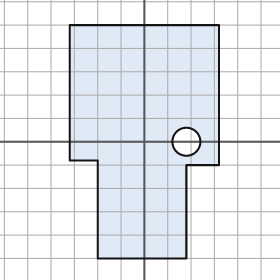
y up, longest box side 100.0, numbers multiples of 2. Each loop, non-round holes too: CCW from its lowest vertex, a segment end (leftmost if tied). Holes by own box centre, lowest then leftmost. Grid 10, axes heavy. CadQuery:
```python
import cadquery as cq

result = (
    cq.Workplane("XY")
    .moveTo(-20.0, -50.0)
    .lineTo(18.0, -50.0)
    .lineTo(18.0, -10.0)
    .lineTo(32.0, -10.0)
    .lineTo(32.0, 50.0)
    .lineTo(-32.0, 50.0)
    .lineTo(-32.0, -8.0)
    .lineTo(-20.0, -8.0)
    .close()
    .moveTo(18.0, 0.0)
    .circle(6.0)
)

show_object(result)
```